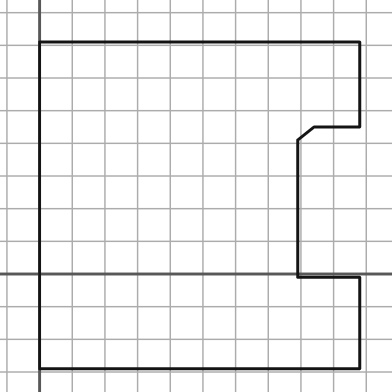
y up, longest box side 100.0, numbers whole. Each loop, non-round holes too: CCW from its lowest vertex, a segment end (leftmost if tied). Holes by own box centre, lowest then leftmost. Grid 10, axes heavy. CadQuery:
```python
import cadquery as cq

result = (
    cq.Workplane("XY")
    .moveTo(0.0, -29.0)
    .lineTo(98.0, -29.0)
    .lineTo(98.0, -1.0)
    .lineTo(79.0, -1.0)
    .lineTo(79.0, 41.0)
    .lineTo(84.0, 45.0)
    .lineTo(98.0, 45.0)
    .lineTo(98.0, 71.0)
    .lineTo(0.0, 71.0)
    .close()
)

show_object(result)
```